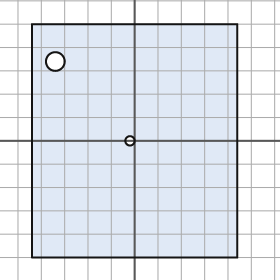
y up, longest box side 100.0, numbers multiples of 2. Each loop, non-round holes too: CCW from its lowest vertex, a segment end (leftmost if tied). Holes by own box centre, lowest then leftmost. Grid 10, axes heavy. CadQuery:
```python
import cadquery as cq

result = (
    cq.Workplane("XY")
    .moveTo(-44.0, -50.0)
    .lineTo(44.0, -50.0)
    .lineTo(44.0, 50.0)
    .lineTo(-44.0, 50.0)
    .close()
    .moveTo(-2.0, 0.0)
    .circle(2.0)
    .moveTo(-34.0, 34.0)
    .circle(4.0)
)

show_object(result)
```